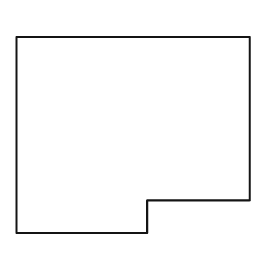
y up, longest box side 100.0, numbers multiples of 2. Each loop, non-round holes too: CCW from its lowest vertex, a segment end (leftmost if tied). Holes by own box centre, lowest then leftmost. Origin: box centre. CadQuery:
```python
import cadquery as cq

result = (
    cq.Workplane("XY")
    .moveTo(-50.0, -42.0)
    .lineTo(6.0, -42.0)
    .lineTo(6.0, -28.0)
    .lineTo(50.0, -28.0)
    .lineTo(50.0, 42.0)
    .lineTo(-50.0, 42.0)
    .close()
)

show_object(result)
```